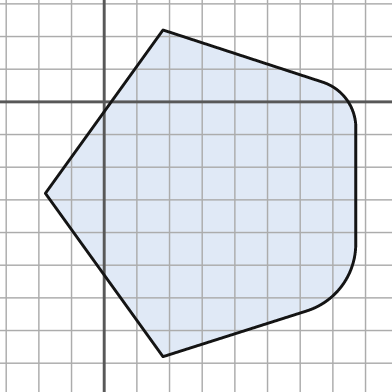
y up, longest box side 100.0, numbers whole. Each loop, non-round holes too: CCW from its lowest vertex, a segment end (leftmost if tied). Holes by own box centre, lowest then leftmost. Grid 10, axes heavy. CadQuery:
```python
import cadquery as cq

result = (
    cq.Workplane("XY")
    .moveTo(18.0, -78.0)
    .lineTo(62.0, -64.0)
    .threePointArc((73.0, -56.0), (77.0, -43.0))
    .lineTo(77.0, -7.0)
    .threePointArc((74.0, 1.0), (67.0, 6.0))
    .lineTo(18.0, 22.0)
    .lineTo(-18.0, -28.0)
    .close()
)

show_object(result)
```